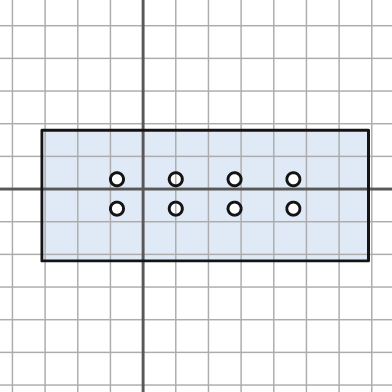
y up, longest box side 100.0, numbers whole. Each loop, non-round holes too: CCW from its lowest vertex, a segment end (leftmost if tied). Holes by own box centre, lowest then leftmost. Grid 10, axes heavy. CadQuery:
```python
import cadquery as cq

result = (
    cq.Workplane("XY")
    .moveTo(-31.0, -22.0)
    .lineTo(69.0, -22.0)
    .lineTo(69.0, 18.0)
    .lineTo(-31.0, 18.0)
    .close()
    .moveTo(-8.0, -6.0)
    .circle(2.0)
    .moveTo(10.0, -6.0)
    .circle(2.0)
    .moveTo(28.0, -6.0)
    .circle(2.0)
    .moveTo(46.0, -6.0)
    .circle(2.0)
    .moveTo(-8.0, 3.0)
    .circle(2.0)
    .moveTo(10.0, 3.0)
    .circle(2.0)
    .moveTo(28.0, 3.0)
    .circle(2.0)
    .moveTo(46.0, 3.0)
    .circle(2.0)
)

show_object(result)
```